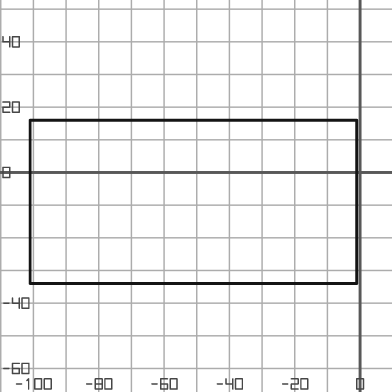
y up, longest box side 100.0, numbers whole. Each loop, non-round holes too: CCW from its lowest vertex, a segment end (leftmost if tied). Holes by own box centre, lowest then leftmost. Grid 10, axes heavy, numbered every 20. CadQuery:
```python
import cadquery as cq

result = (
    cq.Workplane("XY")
    .moveTo(-101.0, -34.0)
    .lineTo(-1.0, -34.0)
    .lineTo(-1.0, 16.0)
    .lineTo(-101.0, 16.0)
    .close()
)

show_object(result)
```